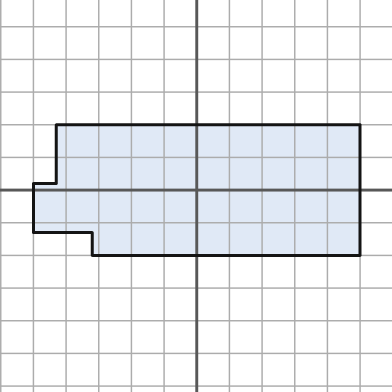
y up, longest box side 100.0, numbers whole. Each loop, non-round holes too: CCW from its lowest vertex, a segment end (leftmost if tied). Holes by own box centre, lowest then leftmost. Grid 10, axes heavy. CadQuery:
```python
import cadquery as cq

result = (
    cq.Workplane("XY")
    .moveTo(-32.0, -20.0)
    .lineTo(50.0, -20.0)
    .lineTo(50.0, 20.0)
    .lineTo(-43.0, 20.0)
    .lineTo(-43.0, 2.0)
    .lineTo(-50.0, 2.0)
    .lineTo(-50.0, -13.0)
    .lineTo(-32.0, -13.0)
    .close()
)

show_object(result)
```